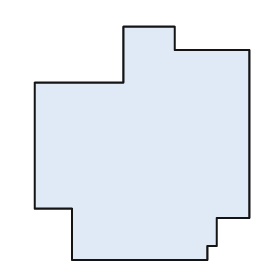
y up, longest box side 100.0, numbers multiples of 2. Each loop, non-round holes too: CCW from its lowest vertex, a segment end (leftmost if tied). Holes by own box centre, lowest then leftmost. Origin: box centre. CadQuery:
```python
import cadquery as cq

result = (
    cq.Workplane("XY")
    .moveTo(-30.0, -50.0)
    .lineTo(28.0, -50.0)
    .lineTo(28.0, -44.0)
    .lineTo(32.0, -44.0)
    .lineTo(32.0, -32.0)
    .lineTo(46.0, -32.0)
    .lineTo(46.0, 40.0)
    .lineTo(14.0, 40.0)
    .lineTo(14.0, 50.0)
    .lineTo(-8.0, 50.0)
    .lineTo(-8.0, 26.0)
    .lineTo(-46.0, 26.0)
    .lineTo(-46.0, -28.0)
    .lineTo(-30.0, -28.0)
    .close()
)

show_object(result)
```